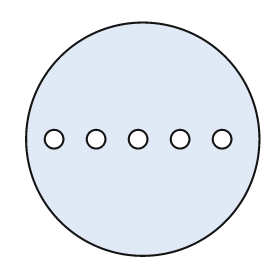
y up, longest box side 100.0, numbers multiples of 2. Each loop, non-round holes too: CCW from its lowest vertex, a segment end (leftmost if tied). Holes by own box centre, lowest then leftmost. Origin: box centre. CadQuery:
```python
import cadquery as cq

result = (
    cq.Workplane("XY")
    .moveTo(0.0, 0.0)
    .circle(50.0)
    .moveTo(-38.0, 0.0)
    .circle(4.0)
    .moveTo(-20.0, 0.0)
    .circle(4.0)
    .moveTo(-2.0, 0.0)
    .circle(4.0)
    .moveTo(16.0, 0.0)
    .circle(4.0)
    .moveTo(34.0, 0.0)
    .circle(4.0)
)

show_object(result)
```